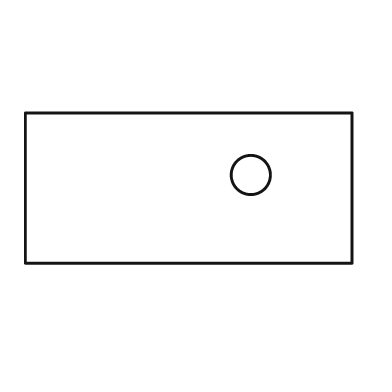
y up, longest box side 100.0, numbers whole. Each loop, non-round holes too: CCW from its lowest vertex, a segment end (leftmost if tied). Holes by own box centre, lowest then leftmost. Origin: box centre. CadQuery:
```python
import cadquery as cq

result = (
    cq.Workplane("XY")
    .moveTo(-50.0, -23.0)
    .lineTo(50.0, -23.0)
    .lineTo(50.0, 23.0)
    .lineTo(-50.0, 23.0)
    .close()
    .moveTo(19.0, 4.0)
    .circle(6.0)
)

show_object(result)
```